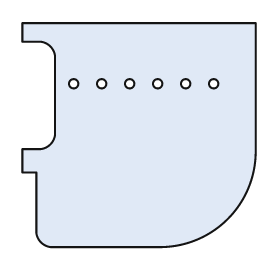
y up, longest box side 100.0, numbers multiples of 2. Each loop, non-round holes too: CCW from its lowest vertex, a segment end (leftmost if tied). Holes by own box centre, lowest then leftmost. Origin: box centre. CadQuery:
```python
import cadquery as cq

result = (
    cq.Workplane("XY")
    .moveTo(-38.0, -48.0)
    .lineTo(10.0, -48.0)
    .threePointArc((38.0, -36.0), (50.0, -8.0))
    .lineTo(50.0, 48.0)
    .lineTo(-50.0, 48.0)
    .lineTo(-50.0, 40.0)
    .lineTo(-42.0, 40.0)
    .threePointArc((-38.0, 38.0), (-36.0, 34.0))
    .lineTo(-36.0, 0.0)
    .threePointArc((-38.0, -4.0), (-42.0, -6.0))
    .lineTo(-50.0, -6.0)
    .lineTo(-50.0, -16.0)
    .lineTo(-44.0, -16.0)
    .lineTo(-44.0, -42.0)
    .threePointArc((-42.0, -46.0), (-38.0, -48.0))
    .close()
    .moveTo(-28.0, 22.0)
    .circle(2.0)
    .moveTo(-16.0, 22.0)
    .circle(2.0)
    .moveTo(-4.0, 22.0)
    .circle(2.0)
    .moveTo(8.0, 22.0)
    .circle(2.0)
    .moveTo(20.0, 22.0)
    .circle(2.0)
    .moveTo(32.0, 22.0)
    .circle(2.0)
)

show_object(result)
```